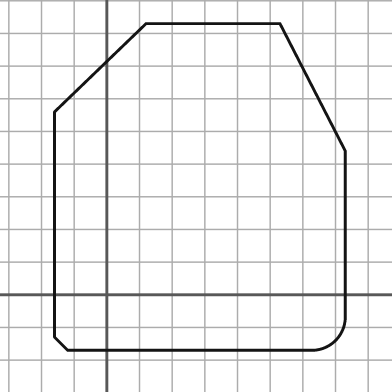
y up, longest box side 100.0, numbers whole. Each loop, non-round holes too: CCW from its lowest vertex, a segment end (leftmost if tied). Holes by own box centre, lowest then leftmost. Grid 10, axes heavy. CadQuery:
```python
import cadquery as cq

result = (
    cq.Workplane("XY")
    .moveTo(-12.0, -17.0)
    .lineTo(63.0, -17.0)
    .threePointArc((70.0, -14.0), (73.0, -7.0))
    .lineTo(73.0, 44.0)
    .lineTo(53.0, 83.0)
    .lineTo(12.0, 83.0)
    .lineTo(-16.0, 56.0)
    .lineTo(-16.0, -13.0)
    .close()
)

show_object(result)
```